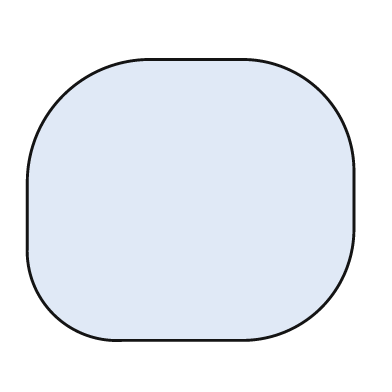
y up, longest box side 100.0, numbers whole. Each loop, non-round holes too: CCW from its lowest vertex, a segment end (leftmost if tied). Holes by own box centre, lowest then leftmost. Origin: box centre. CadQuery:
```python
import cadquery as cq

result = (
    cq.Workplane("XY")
    .moveTo(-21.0, -43.0)
    .lineTo(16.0, -43.0)
    .threePointArc((40.0, -33.0), (50.0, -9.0))
    .lineTo(50.0, 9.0)
    .threePointArc((40.0, 33.0), (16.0, 43.0))
    .lineTo(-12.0, 43.0)
    .threePointArc((-39.0, 32.0), (-50.0, 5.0))
    .lineTo(-50.0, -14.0)
    .threePointArc((-42.0, -35.0), (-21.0, -43.0))
    .close()
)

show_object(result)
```